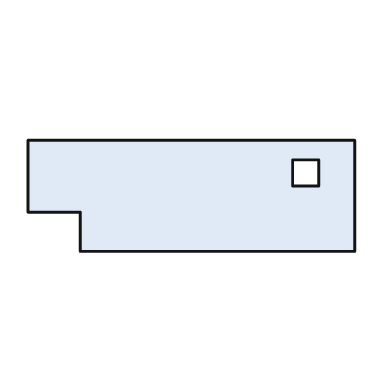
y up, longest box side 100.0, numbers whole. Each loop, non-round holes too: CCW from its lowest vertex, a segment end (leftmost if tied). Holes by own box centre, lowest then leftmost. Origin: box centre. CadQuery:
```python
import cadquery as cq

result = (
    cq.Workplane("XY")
    .moveTo(-34.0, -17.0)
    .lineTo(50.0, -17.0)
    .lineTo(50.0, 17.0)
    .lineTo(-50.0, 17.0)
    .lineTo(-50.0, -5.0)
    .lineTo(-34.0, -5.0)
    .close()
    .moveTo(31.0, 3.0)
    .lineTo(39.0, 3.0)
    .lineTo(39.0, 11.0)
    .lineTo(31.0, 11.0)
    .close()
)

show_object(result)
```